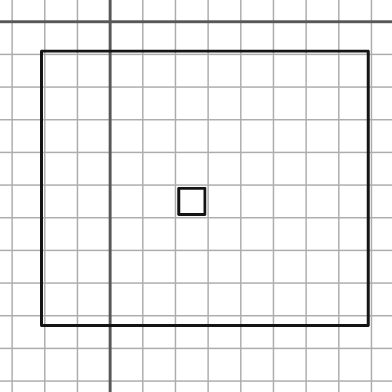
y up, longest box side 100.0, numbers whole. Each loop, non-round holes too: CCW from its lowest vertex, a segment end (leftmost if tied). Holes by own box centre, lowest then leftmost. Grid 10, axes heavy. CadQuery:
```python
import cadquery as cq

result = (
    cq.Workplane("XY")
    .moveTo(-21.0, -93.0)
    .lineTo(79.0, -93.0)
    .lineTo(79.0, -9.0)
    .lineTo(-21.0, -9.0)
    .close()
    .moveTo(21.0, -59.0)
    .lineTo(29.0, -59.0)
    .lineTo(29.0, -51.0)
    .lineTo(21.0, -51.0)
    .close()
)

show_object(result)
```